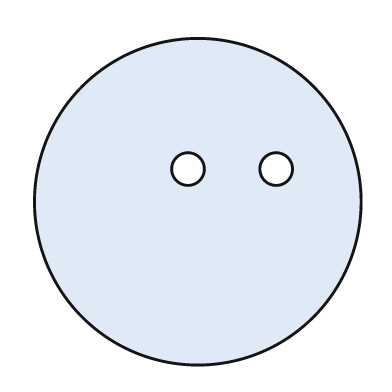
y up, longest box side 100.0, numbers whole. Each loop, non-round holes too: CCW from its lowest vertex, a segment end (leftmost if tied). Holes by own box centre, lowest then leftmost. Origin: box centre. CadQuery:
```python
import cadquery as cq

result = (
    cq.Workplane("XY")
    .moveTo(0.0, 0.0)
    .circle(50.0)
    .moveTo(-3.0, 10.0)
    .circle(5.0)
    .moveTo(24.0, 10.0)
    .circle(5.0)
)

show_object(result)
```